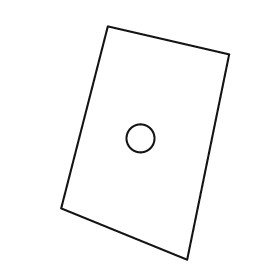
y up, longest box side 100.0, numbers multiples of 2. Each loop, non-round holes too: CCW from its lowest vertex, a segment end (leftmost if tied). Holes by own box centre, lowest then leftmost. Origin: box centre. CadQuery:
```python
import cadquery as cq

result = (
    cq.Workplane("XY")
    .moveTo(18.0, -50.0)
    .lineTo(36.0, 38.0)
    .lineTo(-16.0, 50.0)
    .lineTo(-36.0, -28.0)
    .close()
    .moveTo(-2.0, 2.0)
    .circle(6.0)
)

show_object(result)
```